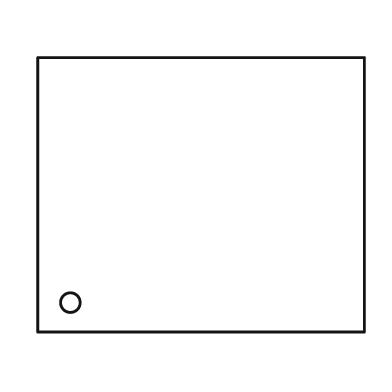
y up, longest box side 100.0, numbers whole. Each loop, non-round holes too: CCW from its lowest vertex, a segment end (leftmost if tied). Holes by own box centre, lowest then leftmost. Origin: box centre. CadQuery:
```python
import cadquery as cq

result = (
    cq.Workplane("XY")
    .moveTo(-50.0, -42.0)
    .lineTo(50.0, -42.0)
    .lineTo(50.0, 42.0)
    .lineTo(-50.0, 42.0)
    .close()
    .moveTo(-40.0, -33.0)
    .circle(3.0)
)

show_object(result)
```